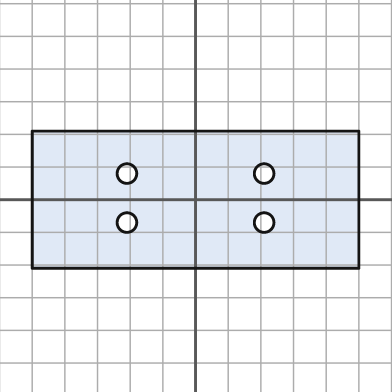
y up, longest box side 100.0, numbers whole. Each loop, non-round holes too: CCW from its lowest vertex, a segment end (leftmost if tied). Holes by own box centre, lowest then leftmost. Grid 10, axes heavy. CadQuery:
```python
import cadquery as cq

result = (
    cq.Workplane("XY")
    .moveTo(-50.0, -21.0)
    .lineTo(50.0, -21.0)
    .lineTo(50.0, 21.0)
    .lineTo(-50.0, 21.0)
    .close()
    .moveTo(-21.0, -7.0)
    .circle(3.0)
    .moveTo(21.0, -7.0)
    .circle(3.0)
    .moveTo(-21.0, 8.0)
    .circle(3.0)
    .moveTo(21.0, 8.0)
    .circle(3.0)
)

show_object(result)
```